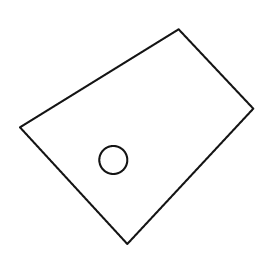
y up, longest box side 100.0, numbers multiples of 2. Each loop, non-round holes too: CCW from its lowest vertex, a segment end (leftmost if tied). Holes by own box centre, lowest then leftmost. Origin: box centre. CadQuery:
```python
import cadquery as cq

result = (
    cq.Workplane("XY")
    .moveTo(-4.0, -46.0)
    .lineTo(50.0, 12.0)
    .lineTo(18.0, 46.0)
    .lineTo(-50.0, 4.0)
    .close()
    .moveTo(-10.0, -10.0)
    .circle(6.0)
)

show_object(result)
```